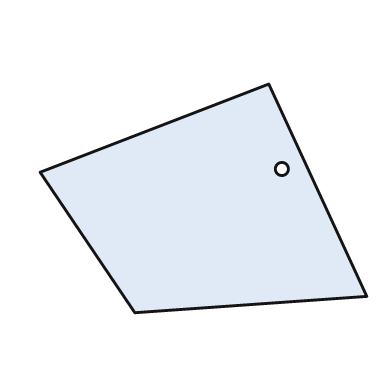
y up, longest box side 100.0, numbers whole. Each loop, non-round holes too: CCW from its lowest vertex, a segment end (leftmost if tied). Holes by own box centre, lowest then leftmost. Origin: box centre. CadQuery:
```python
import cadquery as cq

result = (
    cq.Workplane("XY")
    .moveTo(-21.0, -35.0)
    .lineTo(50.0, -30.0)
    .lineTo(20.0, 35.0)
    .lineTo(-50.0, 8.0)
    .close()
    .moveTo(24.0, 9.0)
    .circle(2.0)
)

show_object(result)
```